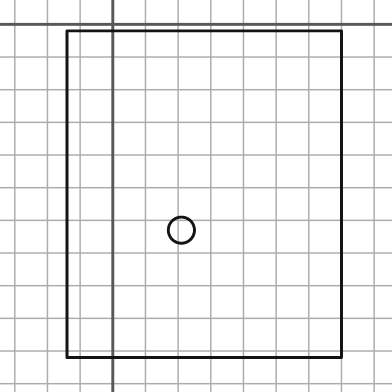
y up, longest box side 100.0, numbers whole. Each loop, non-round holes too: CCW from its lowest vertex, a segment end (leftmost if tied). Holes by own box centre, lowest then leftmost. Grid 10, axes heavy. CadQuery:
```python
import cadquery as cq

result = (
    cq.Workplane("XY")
    .moveTo(-14.0, -102.0)
    .lineTo(70.0, -102.0)
    .lineTo(70.0, -2.0)
    .lineTo(-14.0, -2.0)
    .close()
    .moveTo(21.0, -63.0)
    .circle(4.0)
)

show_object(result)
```